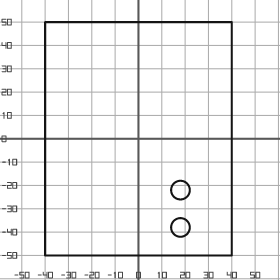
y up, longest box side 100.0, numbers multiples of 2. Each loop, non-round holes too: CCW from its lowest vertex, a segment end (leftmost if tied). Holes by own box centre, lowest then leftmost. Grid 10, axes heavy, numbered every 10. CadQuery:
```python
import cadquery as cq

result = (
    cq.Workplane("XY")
    .moveTo(-40.0, -50.0)
    .lineTo(40.0, -50.0)
    .lineTo(40.0, 50.0)
    .lineTo(-40.0, 50.0)
    .close()
    .moveTo(18.0, -38.0)
    .circle(4.0)
    .moveTo(18.0, -22.0)
    .circle(4.0)
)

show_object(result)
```